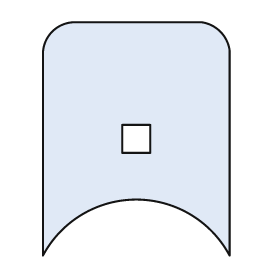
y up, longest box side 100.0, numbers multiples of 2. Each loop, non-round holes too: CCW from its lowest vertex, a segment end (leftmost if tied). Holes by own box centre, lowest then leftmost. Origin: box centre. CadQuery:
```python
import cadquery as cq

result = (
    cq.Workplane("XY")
    .moveTo(-40.0, -50.0)
    .threePointArc((0.0, -26.0), (40.0, -50.0))
    .lineTo(40.0, 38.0)
    .threePointArc((36.0, 46.0), (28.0, 50.0))
    .lineTo(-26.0, 50.0)
    .threePointArc((-36.0, 46.0), (-40.0, 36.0))
    .close()
    .moveTo(-6.0, -6.0)
    .lineTo(6.0, -6.0)
    .lineTo(6.0, 6.0)
    .lineTo(-6.0, 6.0)
    .close()
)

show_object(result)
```